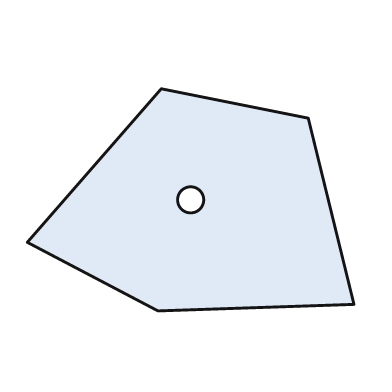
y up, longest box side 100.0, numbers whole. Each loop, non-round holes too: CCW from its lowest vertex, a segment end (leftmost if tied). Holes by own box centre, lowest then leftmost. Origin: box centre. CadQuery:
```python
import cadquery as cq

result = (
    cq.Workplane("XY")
    .moveTo(-10.0, -34.0)
    .lineTo(50.0, -32.0)
    .lineTo(36.0, 25.0)
    .lineTo(-9.0, 34.0)
    .lineTo(-50.0, -13.0)
    .close()
    .moveTo(0.0, 0.0)
    .circle(4.0)
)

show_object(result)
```